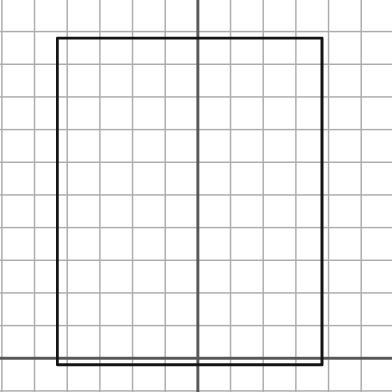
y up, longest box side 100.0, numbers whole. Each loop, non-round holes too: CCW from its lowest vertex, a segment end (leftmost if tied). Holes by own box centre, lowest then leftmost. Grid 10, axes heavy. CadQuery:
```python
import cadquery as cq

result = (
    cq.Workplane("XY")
    .moveTo(-43.0, -2.0)
    .lineTo(38.0, -2.0)
    .lineTo(38.0, 98.0)
    .lineTo(-43.0, 98.0)
    .close()
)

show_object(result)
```